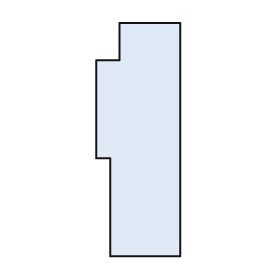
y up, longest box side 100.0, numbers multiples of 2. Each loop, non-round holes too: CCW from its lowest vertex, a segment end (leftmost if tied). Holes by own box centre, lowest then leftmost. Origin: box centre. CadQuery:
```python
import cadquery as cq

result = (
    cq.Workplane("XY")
    .moveTo(-12.0, -50.0)
    .lineTo(18.0, -50.0)
    .lineTo(18.0, 50.0)
    .lineTo(-8.0, 50.0)
    .lineTo(-8.0, 34.0)
    .lineTo(-18.0, 34.0)
    .lineTo(-18.0, -8.0)
    .lineTo(-12.0, -8.0)
    .close()
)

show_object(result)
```